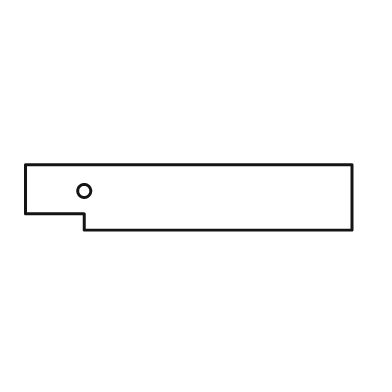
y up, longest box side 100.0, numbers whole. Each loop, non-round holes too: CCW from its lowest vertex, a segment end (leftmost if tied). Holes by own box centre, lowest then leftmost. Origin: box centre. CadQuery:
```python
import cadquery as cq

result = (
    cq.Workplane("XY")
    .moveTo(-32.0, -10.0)
    .lineTo(50.0, -10.0)
    .lineTo(50.0, 10.0)
    .lineTo(-50.0, 10.0)
    .lineTo(-50.0, -5.0)
    .lineTo(-32.0, -5.0)
    .close()
    .moveTo(-32.0, 2.0)
    .circle(2.0)
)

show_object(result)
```